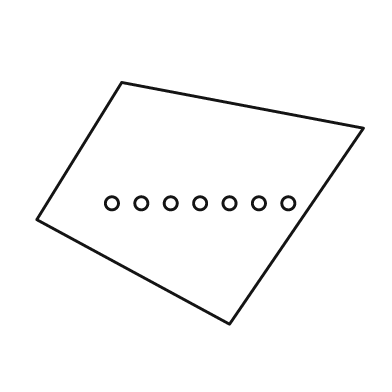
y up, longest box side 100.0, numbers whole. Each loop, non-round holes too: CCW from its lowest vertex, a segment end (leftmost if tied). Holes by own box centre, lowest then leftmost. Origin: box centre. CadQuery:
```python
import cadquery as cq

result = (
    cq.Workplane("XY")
    .moveTo(9.0, -37.0)
    .lineTo(50.0, 23.0)
    .lineTo(-24.0, 37.0)
    .lineTo(-50.0, -5.0)
    .close()
    .moveTo(-27.0, 0.0)
    .circle(2.0)
    .moveTo(-18.0, 0.0)
    .circle(2.0)
    .moveTo(-9.0, 0.0)
    .circle(2.0)
    .moveTo(0.0, 0.0)
    .circle(2.0)
    .moveTo(9.0, 0.0)
    .circle(2.0)
    .moveTo(18.0, 0.0)
    .circle(2.0)
    .moveTo(27.0, 0.0)
    .circle(2.0)
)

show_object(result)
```